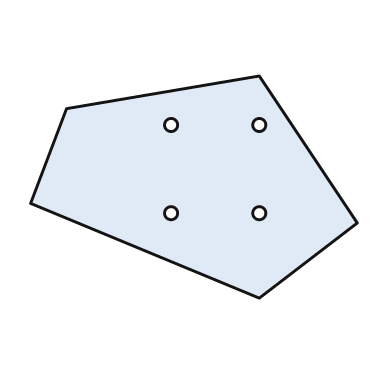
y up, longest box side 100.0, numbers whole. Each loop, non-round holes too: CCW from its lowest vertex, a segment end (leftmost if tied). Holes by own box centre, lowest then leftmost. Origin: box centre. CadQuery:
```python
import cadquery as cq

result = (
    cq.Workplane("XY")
    .moveTo(20.0, -34.0)
    .lineTo(50.0, -11.0)
    .lineTo(20.0, 34.0)
    .lineTo(-39.0, 24.0)
    .lineTo(-50.0, -5.0)
    .close()
    .moveTo(-7.0, -8.0)
    .circle(2.0)
    .moveTo(20.0, -8.0)
    .circle(2.0)
    .moveTo(-7.0, 19.0)
    .circle(2.0)
    .moveTo(20.0, 19.0)
    .circle(2.0)
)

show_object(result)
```